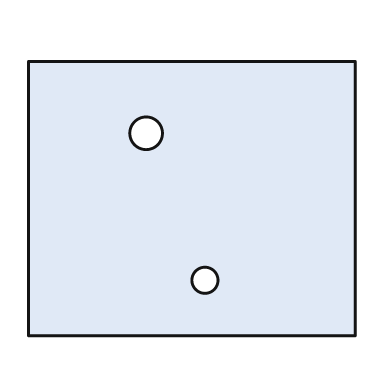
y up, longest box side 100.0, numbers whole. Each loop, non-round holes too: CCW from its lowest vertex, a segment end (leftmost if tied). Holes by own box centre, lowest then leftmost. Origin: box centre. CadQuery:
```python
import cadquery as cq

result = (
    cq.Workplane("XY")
    .moveTo(-50.0, -42.0)
    .lineTo(50.0, -42.0)
    .lineTo(50.0, 42.0)
    .lineTo(-50.0, 42.0)
    .close()
    .moveTo(4.0, -25.0)
    .circle(4.0)
    .moveTo(-14.0, 20.0)
    .circle(5.0)
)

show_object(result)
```